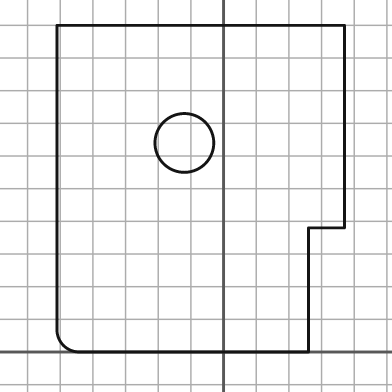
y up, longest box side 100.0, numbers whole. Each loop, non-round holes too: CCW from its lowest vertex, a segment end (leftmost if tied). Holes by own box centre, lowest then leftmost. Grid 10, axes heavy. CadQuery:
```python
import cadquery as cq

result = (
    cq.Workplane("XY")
    .moveTo(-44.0, 0.0)
    .lineTo(26.0, 0.0)
    .lineTo(26.0, 38.0)
    .lineTo(37.0, 38.0)
    .lineTo(37.0, 100.0)
    .lineTo(-51.0, 100.0)
    .lineTo(-51.0, 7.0)
    .threePointArc((-49.0, 2.0), (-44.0, 0.0))
    .close()
    .moveTo(-12.0, 64.0)
    .circle(9.0)
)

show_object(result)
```